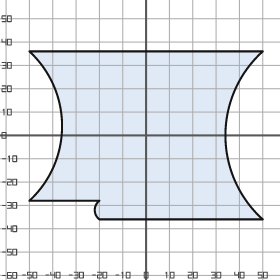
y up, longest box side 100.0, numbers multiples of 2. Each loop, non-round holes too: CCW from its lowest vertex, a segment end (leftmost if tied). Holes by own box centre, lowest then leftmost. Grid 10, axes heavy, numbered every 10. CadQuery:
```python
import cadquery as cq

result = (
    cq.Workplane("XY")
    .moveTo(-20.0, -36.0)
    .lineTo(50.0, -36.0)
    .threePointArc((34.0, 0.0), (50.0, 36.0))
    .lineTo(-50.0, 36.0)
    .threePointArc((-36.0, 4.0), (-50.0, -28.0))
    .lineTo(-20.0, -28.0)
    .threePointArc((-22.0, -32.0), (-20.0, -36.0))
    .close()
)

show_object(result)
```